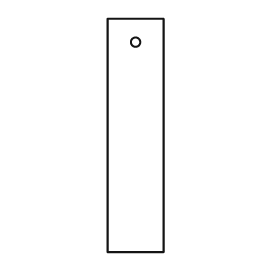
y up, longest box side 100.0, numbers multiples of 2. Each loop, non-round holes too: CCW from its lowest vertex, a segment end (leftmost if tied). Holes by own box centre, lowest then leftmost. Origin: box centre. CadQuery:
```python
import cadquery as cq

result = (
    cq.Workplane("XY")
    .moveTo(-12.0, -50.0)
    .lineTo(12.0, -50.0)
    .lineTo(12.0, 50.0)
    .lineTo(-12.0, 50.0)
    .close()
    .moveTo(0.0, 40.0)
    .circle(2.0)
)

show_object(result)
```